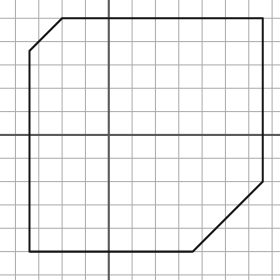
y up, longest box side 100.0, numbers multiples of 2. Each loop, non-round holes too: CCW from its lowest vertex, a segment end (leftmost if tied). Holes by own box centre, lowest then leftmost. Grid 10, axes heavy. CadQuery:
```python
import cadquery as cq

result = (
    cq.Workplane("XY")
    .moveTo(-34.0, -50.0)
    .lineTo(36.0, -50.0)
    .lineTo(66.0, -20.0)
    .lineTo(66.0, 50.0)
    .lineTo(-20.0, 50.0)
    .lineTo(-34.0, 36.0)
    .close()
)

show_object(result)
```